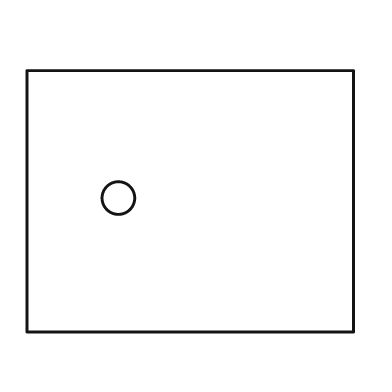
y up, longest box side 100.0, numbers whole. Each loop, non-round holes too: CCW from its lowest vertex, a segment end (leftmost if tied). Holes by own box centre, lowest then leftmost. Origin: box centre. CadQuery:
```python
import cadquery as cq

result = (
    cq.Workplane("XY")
    .moveTo(-50.0, -40.0)
    .lineTo(50.0, -40.0)
    .lineTo(50.0, 40.0)
    .lineTo(-50.0, 40.0)
    .close()
    .moveTo(-22.0, 1.0)
    .circle(5.0)
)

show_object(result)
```